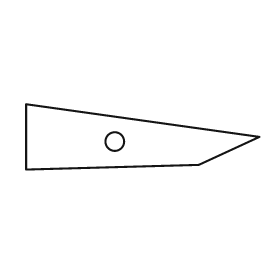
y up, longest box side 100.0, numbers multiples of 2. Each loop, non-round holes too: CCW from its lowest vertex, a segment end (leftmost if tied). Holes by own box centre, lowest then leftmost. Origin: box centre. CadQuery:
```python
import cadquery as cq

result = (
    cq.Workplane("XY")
    .moveTo(-50.0, -14.0)
    .lineTo(24.0, -12.0)
    .lineTo(50.0, 0.0)
    .lineTo(-50.0, 14.0)
    .close()
    .moveTo(-12.0, -2.0)
    .circle(4.0)
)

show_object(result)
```